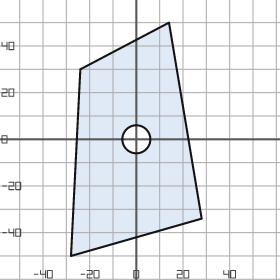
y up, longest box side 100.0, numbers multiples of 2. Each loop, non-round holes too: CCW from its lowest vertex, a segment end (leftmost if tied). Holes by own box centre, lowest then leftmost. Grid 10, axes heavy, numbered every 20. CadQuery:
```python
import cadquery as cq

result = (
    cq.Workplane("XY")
    .moveTo(-28.0, -50.0)
    .lineTo(28.0, -34.0)
    .lineTo(14.0, 50.0)
    .lineTo(-24.0, 30.0)
    .close()
    .moveTo(0.0, 0.0)
    .circle(6.0)
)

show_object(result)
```